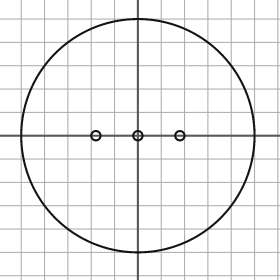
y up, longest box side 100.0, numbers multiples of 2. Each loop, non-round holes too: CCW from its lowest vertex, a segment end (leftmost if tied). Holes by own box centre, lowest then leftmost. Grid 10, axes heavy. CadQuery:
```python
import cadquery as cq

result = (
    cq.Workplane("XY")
    .moveTo(0.0, 0.0)
    .circle(50.0)
    .moveTo(-18.0, 0.0)
    .circle(2.0)
    .moveTo(0.0, 0.0)
    .circle(2.0)
    .moveTo(18.0, 0.0)
    .circle(2.0)
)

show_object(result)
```